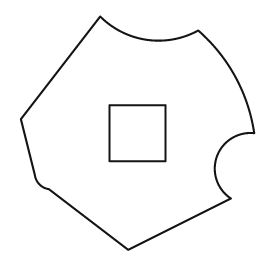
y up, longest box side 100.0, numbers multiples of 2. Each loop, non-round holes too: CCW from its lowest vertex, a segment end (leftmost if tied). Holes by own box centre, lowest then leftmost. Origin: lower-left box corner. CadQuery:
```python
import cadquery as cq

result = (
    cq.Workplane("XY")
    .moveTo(46.0, 0.0)
    .lineTo(90.0, 22.0)
    .threePointArc((84.0, 40.0), (100.0, 50.0))
    .threePointArc((92.0, 74.0), (76.0, 94.0))
    .threePointArc((54.0, 90.0), (34.0, 100.0))
    .lineTo(0.0, 56.0)
    .lineTo(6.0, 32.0)
    .threePointArc((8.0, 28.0), (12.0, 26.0))
    .close()
    .moveTo(38.0, 38.0)
    .lineTo(62.0, 38.0)
    .lineTo(62.0, 62.0)
    .lineTo(38.0, 62.0)
    .close()
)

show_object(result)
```